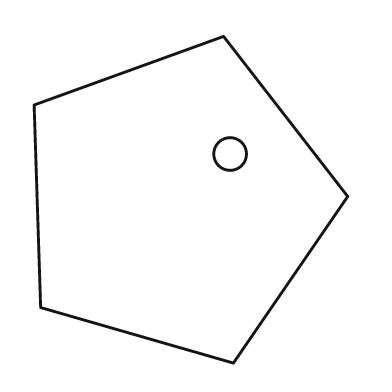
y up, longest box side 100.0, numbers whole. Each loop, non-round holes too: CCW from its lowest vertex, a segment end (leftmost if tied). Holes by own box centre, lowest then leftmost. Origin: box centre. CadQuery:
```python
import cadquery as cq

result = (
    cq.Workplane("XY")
    .moveTo(13.0, -50.0)
    .lineTo(48.0, 1.0)
    .lineTo(10.0, 50.0)
    .lineTo(-48.0, 29.0)
    .lineTo(-46.0, -33.0)
    .close()
    .moveTo(12.0, 14.0)
    .circle(5.0)
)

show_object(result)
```